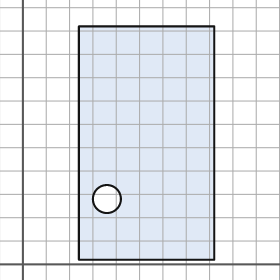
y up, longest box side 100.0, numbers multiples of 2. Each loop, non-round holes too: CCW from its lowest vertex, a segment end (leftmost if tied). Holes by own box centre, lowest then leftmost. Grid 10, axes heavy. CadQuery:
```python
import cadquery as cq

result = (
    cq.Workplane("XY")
    .moveTo(24.0, 2.0)
    .lineTo(82.0, 2.0)
    .lineTo(82.0, 102.0)
    .lineTo(24.0, 102.0)
    .close()
    .moveTo(36.0, 28.0)
    .circle(6.0)
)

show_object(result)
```